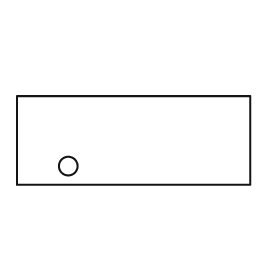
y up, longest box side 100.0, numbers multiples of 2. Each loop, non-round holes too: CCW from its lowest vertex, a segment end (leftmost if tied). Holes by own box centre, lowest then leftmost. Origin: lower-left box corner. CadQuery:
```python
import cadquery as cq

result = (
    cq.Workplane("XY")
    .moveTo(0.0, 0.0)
    .lineTo(100.0, 0.0)
    .lineTo(100.0, 38.0)
    .lineTo(0.0, 38.0)
    .close()
    .moveTo(22.0, 8.0)
    .circle(4.0)
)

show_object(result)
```